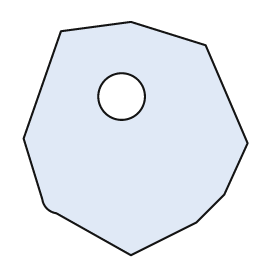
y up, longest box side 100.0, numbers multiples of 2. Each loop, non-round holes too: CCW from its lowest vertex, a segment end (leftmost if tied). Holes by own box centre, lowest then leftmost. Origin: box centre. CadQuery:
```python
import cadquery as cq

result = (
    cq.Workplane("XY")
    .moveTo(-2.0, -50.0)
    .lineTo(26.0, -36.0)
    .lineTo(38.0, -24.0)
    .lineTo(48.0, -2.0)
    .lineTo(30.0, 40.0)
    .lineTo(-2.0, 50.0)
    .lineTo(-32.0, 46.0)
    .lineTo(-48.0, 0.0)
    .lineTo(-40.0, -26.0)
    .threePointArc((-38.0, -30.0), (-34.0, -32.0))
    .close()
    .moveTo(-6.0, 18.0)
    .circle(10.0)
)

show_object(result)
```